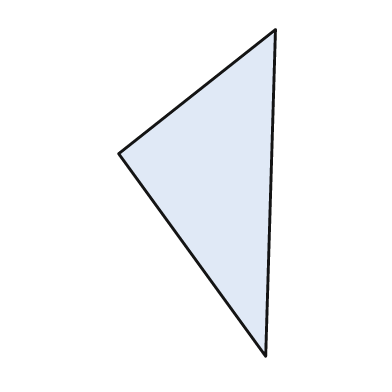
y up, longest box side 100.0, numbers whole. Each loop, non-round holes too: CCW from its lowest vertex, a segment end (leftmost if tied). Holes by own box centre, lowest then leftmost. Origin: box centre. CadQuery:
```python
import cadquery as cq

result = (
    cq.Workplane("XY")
    .moveTo(21.0, -50.0)
    .lineTo(24.0, 50.0)
    .lineTo(-24.0, 12.0)
    .close()
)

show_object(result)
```